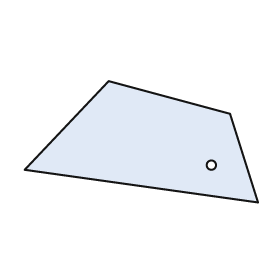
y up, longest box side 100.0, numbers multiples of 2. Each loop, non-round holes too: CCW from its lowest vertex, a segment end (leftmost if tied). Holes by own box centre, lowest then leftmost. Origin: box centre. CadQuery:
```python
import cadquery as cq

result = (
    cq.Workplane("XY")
    .moveTo(50.0, -26.0)
    .lineTo(38.0, 12.0)
    .lineTo(-14.0, 26.0)
    .lineTo(-50.0, -12.0)
    .close()
    .moveTo(30.0, -10.0)
    .circle(2.0)
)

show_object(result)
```